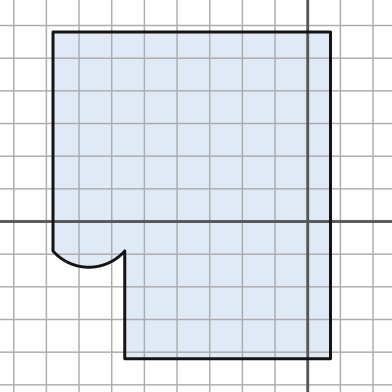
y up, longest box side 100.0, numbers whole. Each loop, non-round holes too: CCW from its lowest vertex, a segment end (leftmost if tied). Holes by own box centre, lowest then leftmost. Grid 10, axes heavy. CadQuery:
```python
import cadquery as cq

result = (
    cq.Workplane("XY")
    .moveTo(-56.0, -42.0)
    .lineTo(7.0, -42.0)
    .lineTo(7.0, 58.0)
    .lineTo(-78.0, 58.0)
    .lineTo(-78.0, -9.0)
    .threePointArc((-67.0, -14.0), (-56.0, -9.0))
    .close()
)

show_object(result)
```